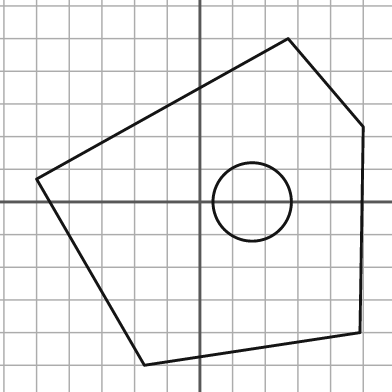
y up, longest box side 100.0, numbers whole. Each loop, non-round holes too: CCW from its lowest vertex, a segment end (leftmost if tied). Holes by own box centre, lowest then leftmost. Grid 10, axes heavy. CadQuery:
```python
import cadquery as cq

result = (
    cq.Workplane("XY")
    .moveTo(-17.0, -50.0)
    .lineTo(49.0, -40.0)
    .lineTo(50.0, 23.0)
    .lineTo(27.0, 50.0)
    .lineTo(-50.0, 7.0)
    .close()
    .moveTo(16.0, 0.0)
    .circle(12.0)
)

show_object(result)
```